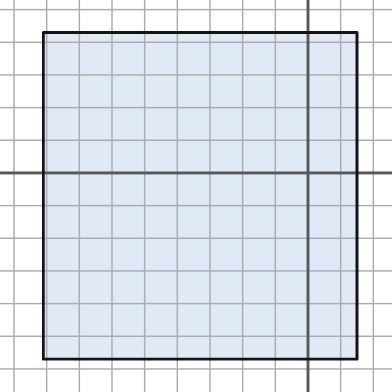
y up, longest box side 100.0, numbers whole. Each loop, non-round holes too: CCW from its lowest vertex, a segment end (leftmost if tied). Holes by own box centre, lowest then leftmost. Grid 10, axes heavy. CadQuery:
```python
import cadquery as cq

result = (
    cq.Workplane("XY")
    .moveTo(-81.0, -57.0)
    .lineTo(15.0, -57.0)
    .lineTo(15.0, 43.0)
    .lineTo(-81.0, 43.0)
    .close()
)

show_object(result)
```